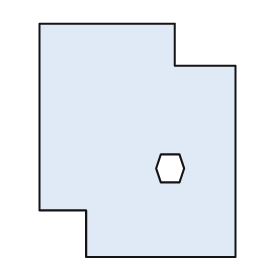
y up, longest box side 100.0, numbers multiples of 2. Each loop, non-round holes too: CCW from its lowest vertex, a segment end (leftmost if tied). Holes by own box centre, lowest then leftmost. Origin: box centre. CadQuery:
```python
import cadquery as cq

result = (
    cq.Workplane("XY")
    .moveTo(-22.0, -50.0)
    .lineTo(42.0, -50.0)
    .lineTo(42.0, 32.0)
    .lineTo(16.0, 32.0)
    .lineTo(16.0, 50.0)
    .lineTo(-42.0, 50.0)
    .lineTo(-42.0, -30.0)
    .lineTo(-22.0, -30.0)
    .close()
    .moveTo(10.0, -18.0)
    .lineTo(18.0, -18.0)
    .lineTo(20.0, -12.0)
    .lineTo(18.0, -6.0)
    .lineTo(10.0, -6.0)
    .lineTo(8.0, -12.0)
    .close()
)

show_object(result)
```